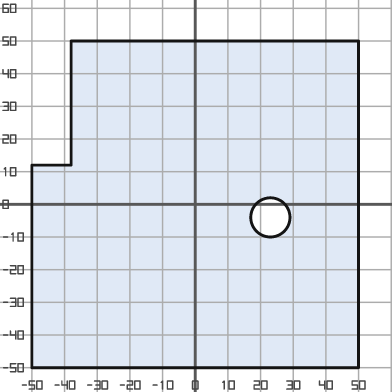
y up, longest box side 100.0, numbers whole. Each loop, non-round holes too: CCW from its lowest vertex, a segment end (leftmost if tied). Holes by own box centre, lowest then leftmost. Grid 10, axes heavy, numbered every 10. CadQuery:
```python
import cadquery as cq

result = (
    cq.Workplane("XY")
    .moveTo(-50.0, -50.0)
    .lineTo(50.0, -50.0)
    .lineTo(50.0, 50.0)
    .lineTo(-38.0, 50.0)
    .lineTo(-38.0, 12.0)
    .lineTo(-50.0, 12.0)
    .close()
    .moveTo(23.0, -4.0)
    .circle(6.0)
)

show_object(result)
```